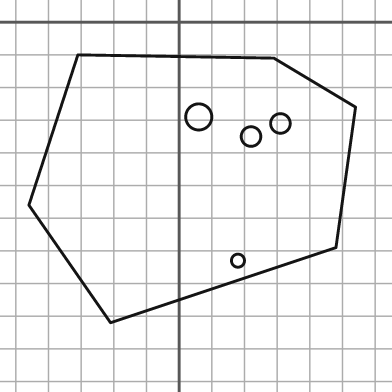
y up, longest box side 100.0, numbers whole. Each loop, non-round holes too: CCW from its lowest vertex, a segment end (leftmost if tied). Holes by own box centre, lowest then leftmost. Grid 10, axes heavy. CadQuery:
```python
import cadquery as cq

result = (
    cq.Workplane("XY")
    .moveTo(-21.0, -92.0)
    .lineTo(48.0, -69.0)
    .lineTo(54.0, -26.0)
    .lineTo(29.0, -11.0)
    .lineTo(-31.0, -10.0)
    .lineTo(-46.0, -56.0)
    .close()
    .moveTo(18.0, -73.0)
    .circle(2.0)
    .moveTo(22.0, -35.0)
    .circle(3.0)
    .moveTo(31.0, -31.0)
    .circle(3.0)
    .moveTo(6.0, -29.0)
    .circle(4.0)
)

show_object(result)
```